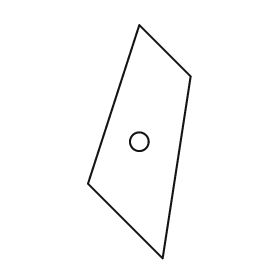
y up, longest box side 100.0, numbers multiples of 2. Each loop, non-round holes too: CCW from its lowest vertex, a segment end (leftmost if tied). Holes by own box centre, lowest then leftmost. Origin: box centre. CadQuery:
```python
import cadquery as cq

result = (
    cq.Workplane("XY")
    .moveTo(10.0, -50.0)
    .lineTo(22.0, 28.0)
    .lineTo(0.0, 50.0)
    .lineTo(-22.0, -18.0)
    .close()
    .moveTo(0.0, 0.0)
    .circle(4.0)
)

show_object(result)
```